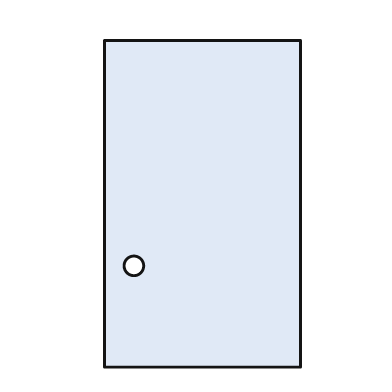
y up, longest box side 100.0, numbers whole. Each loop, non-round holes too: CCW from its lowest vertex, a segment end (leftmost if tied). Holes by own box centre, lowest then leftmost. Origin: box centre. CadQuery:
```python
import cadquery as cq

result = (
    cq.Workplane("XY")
    .moveTo(-30.0, -50.0)
    .lineTo(30.0, -50.0)
    .lineTo(30.0, 50.0)
    .lineTo(-30.0, 50.0)
    .close()
    .moveTo(-21.0, -19.0)
    .circle(3.0)
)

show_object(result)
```